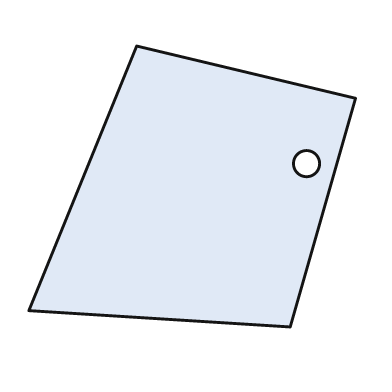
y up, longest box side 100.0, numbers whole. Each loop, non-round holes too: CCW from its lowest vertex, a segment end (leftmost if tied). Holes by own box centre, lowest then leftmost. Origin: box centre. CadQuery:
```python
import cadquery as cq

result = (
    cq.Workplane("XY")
    .moveTo(30.0, -43.0)
    .lineTo(50.0, 27.0)
    .lineTo(-17.0, 43.0)
    .lineTo(-50.0, -38.0)
    .close()
    .moveTo(35.0, 7.0)
    .circle(4.0)
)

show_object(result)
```